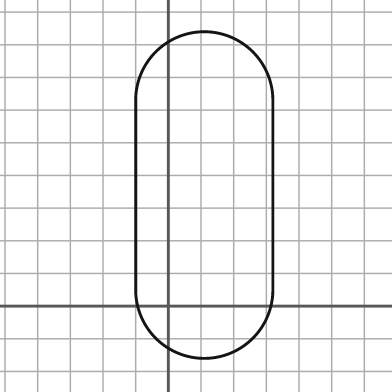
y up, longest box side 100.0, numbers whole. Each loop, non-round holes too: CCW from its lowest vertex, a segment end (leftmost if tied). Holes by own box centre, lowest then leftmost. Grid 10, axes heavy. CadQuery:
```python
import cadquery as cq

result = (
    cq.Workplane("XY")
    .moveTo(-10.0, 5.0)
    .threePointArc((11.0, -16.0), (32.0, 5.0))
    .lineTo(32.0, 63.0)
    .threePointArc((11.0, 84.0), (-10.0, 63.0))
    .close()
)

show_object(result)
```